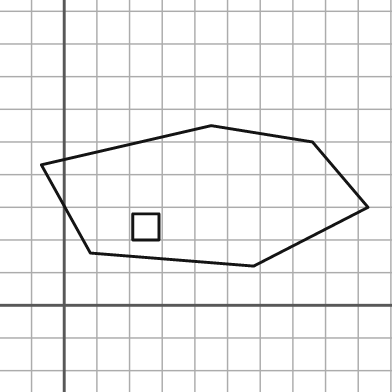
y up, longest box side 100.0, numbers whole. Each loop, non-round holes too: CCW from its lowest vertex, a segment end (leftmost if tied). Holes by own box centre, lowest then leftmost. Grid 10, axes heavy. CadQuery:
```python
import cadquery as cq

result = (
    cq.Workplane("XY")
    .moveTo(58.0, 12.0)
    .lineTo(93.0, 30.0)
    .lineTo(76.0, 50.0)
    .lineTo(45.0, 55.0)
    .lineTo(-7.0, 43.0)
    .lineTo(8.0, 16.0)
    .close()
    .moveTo(21.0, 20.0)
    .lineTo(29.0, 20.0)
    .lineTo(29.0, 28.0)
    .lineTo(21.0, 28.0)
    .close()
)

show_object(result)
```